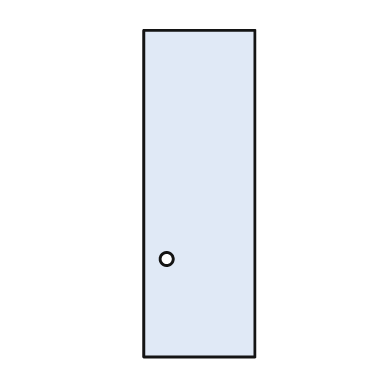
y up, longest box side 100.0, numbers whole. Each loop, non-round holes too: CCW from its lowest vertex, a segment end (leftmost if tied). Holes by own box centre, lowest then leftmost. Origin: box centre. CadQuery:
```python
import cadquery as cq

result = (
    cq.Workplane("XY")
    .moveTo(-17.0, -50.0)
    .lineTo(17.0, -50.0)
    .lineTo(17.0, 50.0)
    .lineTo(-17.0, 50.0)
    .close()
    .moveTo(-10.0, -20.0)
    .circle(2.0)
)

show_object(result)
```